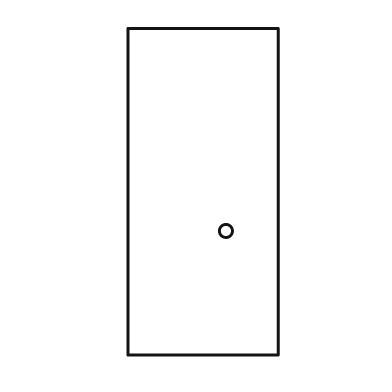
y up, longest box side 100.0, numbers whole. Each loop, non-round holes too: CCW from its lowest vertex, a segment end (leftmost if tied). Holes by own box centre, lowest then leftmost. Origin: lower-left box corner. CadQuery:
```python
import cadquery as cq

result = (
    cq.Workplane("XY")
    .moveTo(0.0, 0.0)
    .lineTo(46.0, 0.0)
    .lineTo(46.0, 100.0)
    .lineTo(0.0, 100.0)
    .close()
    .moveTo(30.0, 38.0)
    .circle(2.0)
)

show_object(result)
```